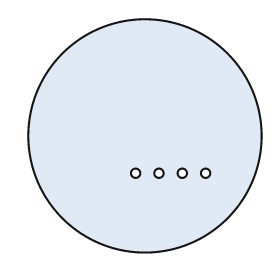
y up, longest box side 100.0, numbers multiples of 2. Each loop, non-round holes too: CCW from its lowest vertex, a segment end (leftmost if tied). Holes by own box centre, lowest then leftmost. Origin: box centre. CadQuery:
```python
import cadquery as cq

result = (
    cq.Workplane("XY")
    .moveTo(0.0, 0.0)
    .circle(50.0)
    .moveTo(-4.0, -16.0)
    .circle(2.0)
    .moveTo(6.0, -16.0)
    .circle(2.0)
    .moveTo(16.0, -16.0)
    .circle(2.0)
    .moveTo(26.0, -16.0)
    .circle(2.0)
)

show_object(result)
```